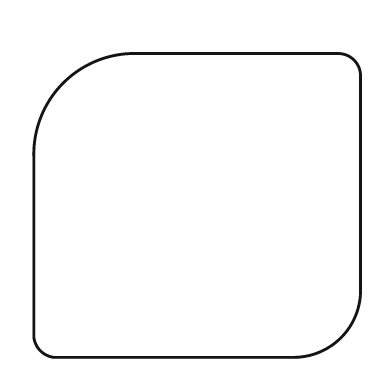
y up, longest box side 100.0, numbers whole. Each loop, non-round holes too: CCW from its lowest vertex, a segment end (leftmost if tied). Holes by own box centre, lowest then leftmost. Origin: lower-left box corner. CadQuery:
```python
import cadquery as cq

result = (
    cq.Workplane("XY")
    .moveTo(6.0, 0.0)
    .lineTo(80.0, 0.0)
    .threePointArc((94.0, 6.0), (100.0, 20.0))
    .lineTo(100.0, 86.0)
    .threePointArc((98.0, 91.0), (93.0, 93.0))
    .lineTo(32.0, 93.0)
    .threePointArc((9.0, 84.0), (0.0, 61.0))
    .lineTo(0.0, 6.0)
    .threePointArc((2.0, 2.0), (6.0, 0.0))
    .close()
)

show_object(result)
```